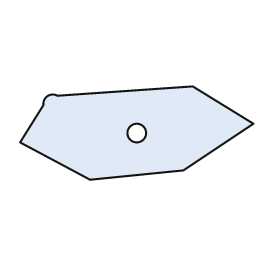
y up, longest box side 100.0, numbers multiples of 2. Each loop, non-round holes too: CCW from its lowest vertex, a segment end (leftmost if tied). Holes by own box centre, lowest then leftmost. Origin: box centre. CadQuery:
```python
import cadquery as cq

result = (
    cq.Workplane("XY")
    .moveTo(-20.0, -20.0)
    .lineTo(20.0, -16.0)
    .lineTo(50.0, 4.0)
    .lineTo(24.0, 20.0)
    .lineTo(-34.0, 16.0)
    .threePointArc((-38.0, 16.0), (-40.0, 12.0))
    .lineTo(-50.0, -4.0)
    .close()
    .moveTo(0.0, 0.0)
    .circle(4.0)
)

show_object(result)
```